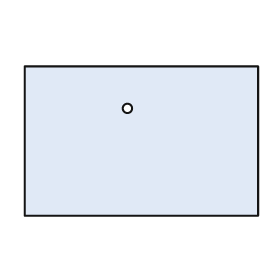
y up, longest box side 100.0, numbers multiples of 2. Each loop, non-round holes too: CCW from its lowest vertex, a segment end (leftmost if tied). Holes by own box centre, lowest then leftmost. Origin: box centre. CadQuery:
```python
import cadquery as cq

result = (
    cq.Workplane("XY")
    .moveTo(-50.0, -32.0)
    .lineTo(50.0, -32.0)
    .lineTo(50.0, 32.0)
    .lineTo(-50.0, 32.0)
    .close()
    .moveTo(-6.0, 14.0)
    .circle(2.0)
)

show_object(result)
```